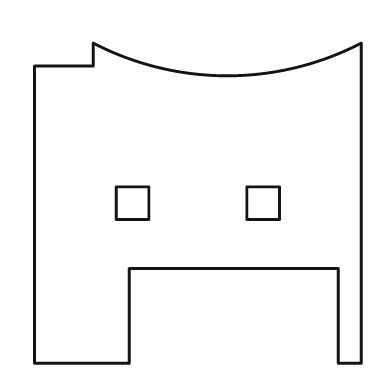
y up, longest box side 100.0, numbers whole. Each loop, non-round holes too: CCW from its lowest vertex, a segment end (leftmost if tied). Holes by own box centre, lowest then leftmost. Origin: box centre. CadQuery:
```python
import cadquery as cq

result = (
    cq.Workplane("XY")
    .moveTo(-50.0, -49.0)
    .lineTo(-21.0, -49.0)
    .lineTo(-21.0, -20.0)
    .lineTo(43.0, -20.0)
    .lineTo(43.0, -49.0)
    .lineTo(50.0, -49.0)
    .lineTo(50.0, 49.0)
    .threePointArc((9.0, 39.0), (-32.0, 49.0))
    .lineTo(-32.0, 42.0)
    .lineTo(-50.0, 42.0)
    .close()
    .moveTo(-25.0, -5.0)
    .lineTo(-15.0, -5.0)
    .lineTo(-15.0, 5.0)
    .lineTo(-25.0, 5.0)
    .close()
    .moveTo(15.0, -5.0)
    .lineTo(25.0, -5.0)
    .lineTo(25.0, 5.0)
    .lineTo(15.0, 5.0)
    .close()
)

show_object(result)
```